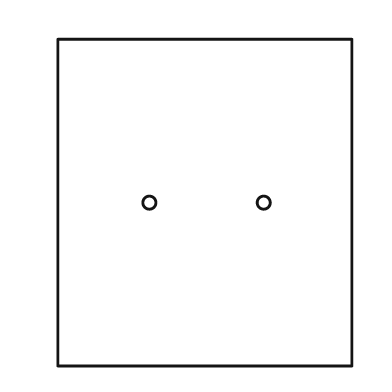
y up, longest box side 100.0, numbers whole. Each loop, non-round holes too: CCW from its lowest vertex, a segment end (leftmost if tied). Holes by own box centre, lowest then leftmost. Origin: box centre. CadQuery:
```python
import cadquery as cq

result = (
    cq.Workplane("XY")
    .moveTo(-45.0, -50.0)
    .lineTo(45.0, -50.0)
    .lineTo(45.0, 50.0)
    .lineTo(-45.0, 50.0)
    .close()
    .moveTo(-17.0, 0.0)
    .circle(2.0)
    .moveTo(18.0, 0.0)
    .circle(2.0)
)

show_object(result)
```